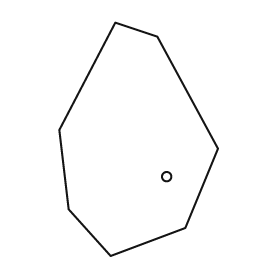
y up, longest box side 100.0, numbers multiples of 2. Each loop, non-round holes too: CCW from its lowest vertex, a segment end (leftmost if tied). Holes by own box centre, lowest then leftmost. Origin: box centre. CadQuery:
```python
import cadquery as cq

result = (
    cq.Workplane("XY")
    .moveTo(-12.0, -50.0)
    .lineTo(20.0, -38.0)
    .lineTo(34.0, -4.0)
    .lineTo(8.0, 44.0)
    .lineTo(-10.0, 50.0)
    .lineTo(-34.0, 4.0)
    .lineTo(-30.0, -30.0)
    .close()
    .moveTo(12.0, -16.0)
    .circle(2.0)
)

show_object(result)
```